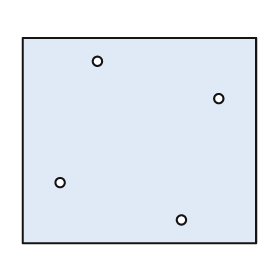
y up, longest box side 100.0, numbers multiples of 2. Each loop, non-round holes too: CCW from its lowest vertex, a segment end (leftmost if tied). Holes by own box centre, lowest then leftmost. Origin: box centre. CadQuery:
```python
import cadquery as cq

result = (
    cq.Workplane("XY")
    .moveTo(-50.0, -44.0)
    .lineTo(50.0, -44.0)
    .lineTo(50.0, 44.0)
    .lineTo(-50.0, 44.0)
    .close()
    .moveTo(18.0, -34.0)
    .circle(2.0)
    .moveTo(-34.0, -18.0)
    .circle(2.0)
    .moveTo(34.0, 18.0)
    .circle(2.0)
    .moveTo(-18.0, 34.0)
    .circle(2.0)
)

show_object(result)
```